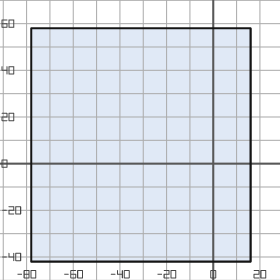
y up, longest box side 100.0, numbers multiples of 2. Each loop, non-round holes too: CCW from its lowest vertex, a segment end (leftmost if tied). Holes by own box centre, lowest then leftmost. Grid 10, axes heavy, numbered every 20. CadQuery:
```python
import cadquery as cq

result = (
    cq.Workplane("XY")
    .moveTo(-78.0, -42.0)
    .lineTo(16.0, -42.0)
    .lineTo(16.0, 58.0)
    .lineTo(-78.0, 58.0)
    .close()
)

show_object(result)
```